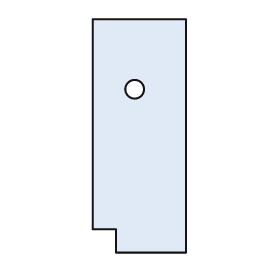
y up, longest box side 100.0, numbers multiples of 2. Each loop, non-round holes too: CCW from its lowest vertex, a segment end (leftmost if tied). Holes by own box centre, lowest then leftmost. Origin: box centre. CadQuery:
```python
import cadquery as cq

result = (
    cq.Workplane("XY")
    .moveTo(-10.0, -50.0)
    .lineTo(20.0, -50.0)
    .lineTo(20.0, 50.0)
    .lineTo(-20.0, 50.0)
    .lineTo(-20.0, -40.0)
    .lineTo(-10.0, -40.0)
    .close()
    .moveTo(-2.0, 20.0)
    .circle(4.0)
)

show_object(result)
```